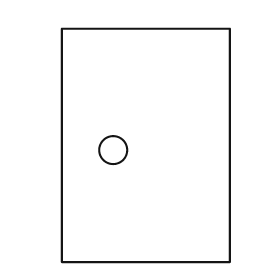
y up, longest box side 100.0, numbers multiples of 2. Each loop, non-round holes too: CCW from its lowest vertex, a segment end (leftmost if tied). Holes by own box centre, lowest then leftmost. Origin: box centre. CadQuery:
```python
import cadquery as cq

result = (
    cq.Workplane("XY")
    .moveTo(-36.0, -50.0)
    .lineTo(36.0, -50.0)
    .lineTo(36.0, 50.0)
    .lineTo(-36.0, 50.0)
    .close()
    .moveTo(-14.0, -2.0)
    .circle(6.0)
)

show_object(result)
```